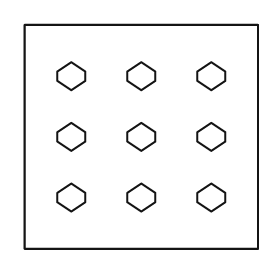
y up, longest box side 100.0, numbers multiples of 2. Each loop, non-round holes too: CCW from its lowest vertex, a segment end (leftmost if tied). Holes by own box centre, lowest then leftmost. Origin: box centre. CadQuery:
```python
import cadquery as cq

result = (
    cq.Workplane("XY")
    .moveTo(-50.0, -48.0)
    .lineTo(50.0, -48.0)
    .lineTo(50.0, 48.0)
    .lineTo(-50.0, 48.0)
    .close()
    .moveTo(-30.0, -32.0)
    .lineTo(-24.0, -28.0)
    .lineTo(-24.0, -24.0)
    .lineTo(-30.0, -20.0)
    .lineTo(-36.0, -24.0)
    .lineTo(-36.0, -28.0)
    .close()
    .moveTo(0.0, -32.0)
    .lineTo(6.0, -28.0)
    .lineTo(6.0, -24.0)
    .lineTo(0.0, -20.0)
    .lineTo(-6.0, -24.0)
    .lineTo(-6.0, -28.0)
    .close()
    .moveTo(30.0, -32.0)
    .lineTo(36.0, -28.0)
    .lineTo(36.0, -24.0)
    .lineTo(30.0, -20.0)
    .lineTo(24.0, -24.0)
    .lineTo(24.0, -28.0)
    .close()
    .moveTo(-30.0, -6.0)
    .lineTo(-24.0, -2.0)
    .lineTo(-24.0, 2.0)
    .lineTo(-30.0, 6.0)
    .lineTo(-36.0, 2.0)
    .lineTo(-36.0, -2.0)
    .close()
    .moveTo(0.0, -6.0)
    .lineTo(6.0, -2.0)
    .lineTo(6.0, 2.0)
    .lineTo(0.0, 6.0)
    .lineTo(-6.0, 2.0)
    .lineTo(-6.0, -2.0)
    .close()
    .moveTo(30.0, -6.0)
    .lineTo(36.0, -2.0)
    .lineTo(36.0, 2.0)
    .lineTo(30.0, 6.0)
    .lineTo(24.0, 2.0)
    .lineTo(24.0, -2.0)
    .close()
    .moveTo(-30.0, 20.0)
    .lineTo(-24.0, 24.0)
    .lineTo(-24.0, 28.0)
    .lineTo(-30.0, 32.0)
    .lineTo(-36.0, 28.0)
    .lineTo(-36.0, 24.0)
    .close()
    .moveTo(0.0, 20.0)
    .lineTo(6.0, 24.0)
    .lineTo(6.0, 28.0)
    .lineTo(0.0, 32.0)
    .lineTo(-6.0, 28.0)
    .lineTo(-6.0, 24.0)
    .close()
    .moveTo(30.0, 20.0)
    .lineTo(36.0, 24.0)
    .lineTo(36.0, 28.0)
    .lineTo(30.0, 32.0)
    .lineTo(24.0, 28.0)
    .lineTo(24.0, 24.0)
    .close()
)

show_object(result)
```